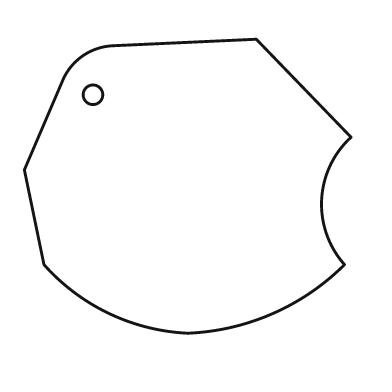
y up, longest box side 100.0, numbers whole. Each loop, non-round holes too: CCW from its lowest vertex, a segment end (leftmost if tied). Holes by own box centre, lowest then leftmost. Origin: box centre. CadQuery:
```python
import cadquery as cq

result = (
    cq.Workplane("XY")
    .moveTo(0.0, -45.0)
    .threePointArc((26.0, -39.0), (48.0, -24.0))
    .threePointArc((41.0, -4.0), (50.0, 15.0))
    .lineTo(21.0, 45.0)
    .lineTo(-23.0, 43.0)
    .threePointArc((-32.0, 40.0), (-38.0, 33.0))
    .lineTo(-50.0, 5.0)
    .lineTo(-44.0, -24.0)
    .threePointArc((-24.0, -39.0), (0.0, -45.0))
    .close()
    .moveTo(-29.0, 28.0)
    .circle(3.0)
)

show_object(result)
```